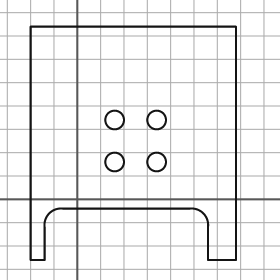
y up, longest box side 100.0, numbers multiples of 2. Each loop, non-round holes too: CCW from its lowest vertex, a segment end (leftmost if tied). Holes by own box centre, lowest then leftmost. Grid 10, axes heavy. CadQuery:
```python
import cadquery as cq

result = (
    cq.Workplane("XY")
    .moveTo(-20.0, -26.0)
    .lineTo(-14.0, -26.0)
    .lineTo(-14.0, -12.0)
    .threePointArc((-12.0, -6.0), (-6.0, -4.0))
    .lineTo(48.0, -4.0)
    .threePointArc((54.0, -6.0), (56.0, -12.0))
    .lineTo(56.0, -26.0)
    .lineTo(68.0, -26.0)
    .lineTo(68.0, 74.0)
    .lineTo(-20.0, 74.0)
    .close()
    .moveTo(16.0, 16.0)
    .circle(4.0)
    .moveTo(34.0, 16.0)
    .circle(4.0)
    .moveTo(16.0, 34.0)
    .circle(4.0)
    .moveTo(34.0, 34.0)
    .circle(4.0)
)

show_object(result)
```